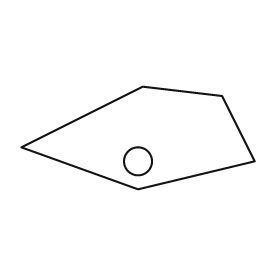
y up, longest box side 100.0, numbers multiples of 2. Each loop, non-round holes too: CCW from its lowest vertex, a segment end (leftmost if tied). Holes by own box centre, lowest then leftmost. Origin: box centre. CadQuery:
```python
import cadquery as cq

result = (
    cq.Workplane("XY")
    .moveTo(0.0, -22.0)
    .lineTo(50.0, -10.0)
    .lineTo(36.0, 18.0)
    .lineTo(2.0, 22.0)
    .lineTo(-50.0, -4.0)
    .close()
    .moveTo(0.0, -10.0)
    .circle(6.0)
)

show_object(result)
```